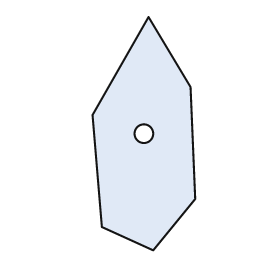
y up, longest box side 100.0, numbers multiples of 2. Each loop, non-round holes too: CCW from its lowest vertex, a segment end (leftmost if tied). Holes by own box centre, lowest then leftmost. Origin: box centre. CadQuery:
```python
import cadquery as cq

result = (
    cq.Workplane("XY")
    .moveTo(4.0, -50.0)
    .lineTo(22.0, -28.0)
    .lineTo(20.0, 20.0)
    .lineTo(2.0, 50.0)
    .lineTo(-22.0, 8.0)
    .lineTo(-18.0, -40.0)
    .close()
    .moveTo(0.0, 0.0)
    .circle(4.0)
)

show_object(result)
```